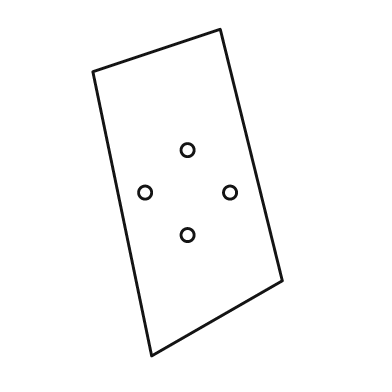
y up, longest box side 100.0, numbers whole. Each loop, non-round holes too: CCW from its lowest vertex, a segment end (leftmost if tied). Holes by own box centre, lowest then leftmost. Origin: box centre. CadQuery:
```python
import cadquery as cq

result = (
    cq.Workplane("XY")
    .moveTo(-11.0, -50.0)
    .lineTo(29.0, -27.0)
    .lineTo(10.0, 50.0)
    .lineTo(-29.0, 37.0)
    .close()
    .moveTo(0.0, -13.0)
    .circle(2.0)
    .moveTo(-13.0, 0.0)
    .circle(2.0)
    .moveTo(13.0, 0.0)
    .circle(2.0)
    .moveTo(0.0, 13.0)
    .circle(2.0)
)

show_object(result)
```